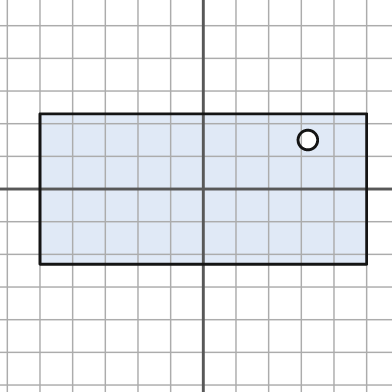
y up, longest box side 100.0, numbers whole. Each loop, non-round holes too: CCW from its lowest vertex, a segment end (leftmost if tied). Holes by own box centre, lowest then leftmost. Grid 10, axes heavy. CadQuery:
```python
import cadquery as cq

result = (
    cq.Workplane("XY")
    .moveTo(-50.0, -23.0)
    .lineTo(50.0, -23.0)
    .lineTo(50.0, 23.0)
    .lineTo(-50.0, 23.0)
    .close()
    .moveTo(32.0, 15.0)
    .circle(3.0)
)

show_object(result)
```